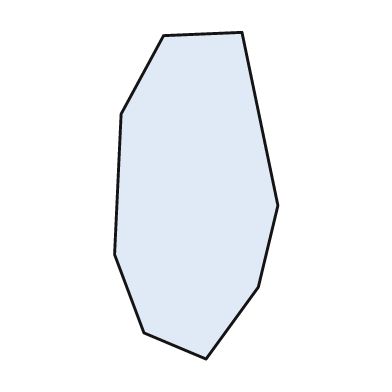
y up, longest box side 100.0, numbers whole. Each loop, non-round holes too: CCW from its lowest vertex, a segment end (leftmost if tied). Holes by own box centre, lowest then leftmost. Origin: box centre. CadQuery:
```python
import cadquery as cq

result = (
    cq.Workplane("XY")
    .moveTo(3.0, -50.0)
    .lineTo(19.0, -28.0)
    .lineTo(25.0, -3.0)
    .lineTo(14.0, 50.0)
    .lineTo(-10.0, 49.0)
    .lineTo(-23.0, 25.0)
    .lineTo(-25.0, -18.0)
    .lineTo(-16.0, -42.0)
    .close()
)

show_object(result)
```